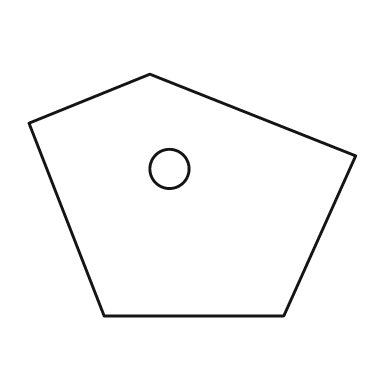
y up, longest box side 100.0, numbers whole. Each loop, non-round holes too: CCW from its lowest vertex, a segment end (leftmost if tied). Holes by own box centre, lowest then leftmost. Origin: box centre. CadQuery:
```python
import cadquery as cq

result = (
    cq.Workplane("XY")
    .moveTo(-27.0, -37.0)
    .lineTo(28.0, -37.0)
    .lineTo(50.0, 12.0)
    .lineTo(-13.0, 37.0)
    .lineTo(-50.0, 22.0)
    .close()
    .moveTo(-7.0, 8.0)
    .circle(6.0)
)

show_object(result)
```